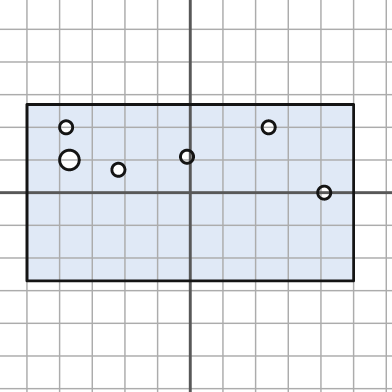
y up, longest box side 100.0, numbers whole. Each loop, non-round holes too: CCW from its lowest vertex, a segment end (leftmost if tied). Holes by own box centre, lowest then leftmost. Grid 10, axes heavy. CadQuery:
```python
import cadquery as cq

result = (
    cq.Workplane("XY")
    .moveTo(-50.0, -27.0)
    .lineTo(50.0, -27.0)
    .lineTo(50.0, 27.0)
    .lineTo(-50.0, 27.0)
    .close()
    .moveTo(41.0, 0.0)
    .circle(2.0)
    .moveTo(-22.0, 7.0)
    .circle(2.0)
    .moveTo(-37.0, 10.0)
    .circle(3.0)
    .moveTo(-1.0, 11.0)
    .circle(2.0)
    .moveTo(-38.0, 20.0)
    .circle(2.0)
    .moveTo(24.0, 20.0)
    .circle(2.0)
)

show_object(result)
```